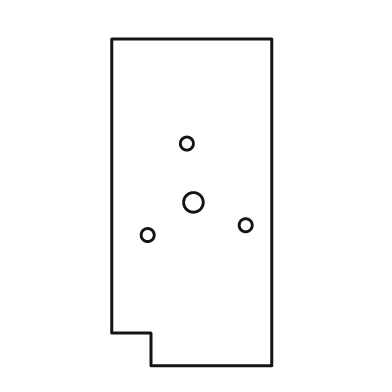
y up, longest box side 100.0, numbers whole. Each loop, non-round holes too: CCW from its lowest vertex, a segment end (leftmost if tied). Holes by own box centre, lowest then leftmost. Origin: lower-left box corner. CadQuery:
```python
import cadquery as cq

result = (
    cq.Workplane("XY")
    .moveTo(12.0, 0.0)
    .lineTo(49.0, 0.0)
    .lineTo(49.0, 100.0)
    .lineTo(0.0, 100.0)
    .lineTo(0.0, 10.0)
    .lineTo(12.0, 10.0)
    .close()
    .moveTo(11.0, 40.0)
    .circle(2.0)
    .moveTo(41.0, 43.0)
    .circle(2.0)
    .moveTo(25.0, 50.0)
    .circle(3.0)
    .moveTo(23.0, 68.0)
    .circle(2.0)
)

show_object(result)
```